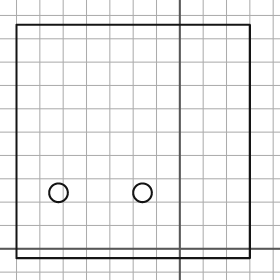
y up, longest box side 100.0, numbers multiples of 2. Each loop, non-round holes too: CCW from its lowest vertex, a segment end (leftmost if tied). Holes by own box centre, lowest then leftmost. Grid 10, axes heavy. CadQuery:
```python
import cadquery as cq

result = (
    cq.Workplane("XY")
    .moveTo(-70.0, -4.0)
    .lineTo(30.0, -4.0)
    .lineTo(30.0, 96.0)
    .lineTo(-70.0, 96.0)
    .close()
    .moveTo(-52.0, 24.0)
    .circle(4.0)
    .moveTo(-16.0, 24.0)
    .circle(4.0)
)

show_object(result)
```